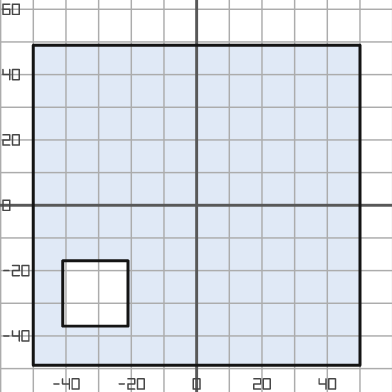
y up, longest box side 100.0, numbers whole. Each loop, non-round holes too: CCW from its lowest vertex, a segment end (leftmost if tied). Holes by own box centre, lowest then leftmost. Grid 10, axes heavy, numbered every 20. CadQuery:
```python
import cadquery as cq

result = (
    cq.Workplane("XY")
    .moveTo(-50.0, -49.0)
    .lineTo(50.0, -49.0)
    .lineTo(50.0, 49.0)
    .lineTo(-50.0, 49.0)
    .close()
    .moveTo(-41.0, -37.0)
    .lineTo(-21.0, -37.0)
    .lineTo(-21.0, -17.0)
    .lineTo(-41.0, -17.0)
    .close()
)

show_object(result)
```